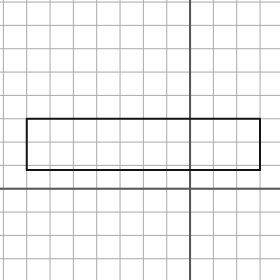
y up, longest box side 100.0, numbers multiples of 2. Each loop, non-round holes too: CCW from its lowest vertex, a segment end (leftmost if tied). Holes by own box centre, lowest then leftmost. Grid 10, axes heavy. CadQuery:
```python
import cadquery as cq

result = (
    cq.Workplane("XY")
    .moveTo(-70.0, 8.0)
    .lineTo(30.0, 8.0)
    .lineTo(30.0, 30.0)
    .lineTo(-70.0, 30.0)
    .close()
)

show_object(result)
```